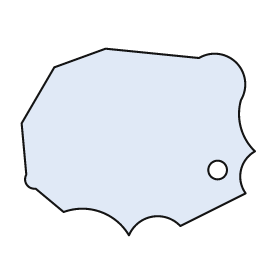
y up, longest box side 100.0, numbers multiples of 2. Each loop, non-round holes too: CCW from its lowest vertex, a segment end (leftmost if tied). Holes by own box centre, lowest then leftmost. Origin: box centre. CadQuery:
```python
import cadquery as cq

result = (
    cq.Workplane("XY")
    .moveTo(-4.0, -40.0)
    .threePointArc((6.0, -32.0), (18.0, -36.0))
    .lineTo(46.0, -22.0)
    .threePointArc((44.0, -12.0), (50.0, -4.0))
    .threePointArc((44.0, 6.0), (44.0, 18.0))
    .threePointArc((42.0, 34.0), (26.0, 36.0))
    .lineTo(-14.0, 40.0)
    .lineTo(-36.0, 32.0)
    .lineTo(-50.0, 8.0)
    .lineTo(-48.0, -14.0)
    .threePointArc((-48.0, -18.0), (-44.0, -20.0))
    .lineTo(-32.0, -30.0)
    .threePointArc((-16.0, -30.0), (-4.0, -40.0))
    .close()
    .moveTo(34.0, -12.0)
    .circle(4.0)
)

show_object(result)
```